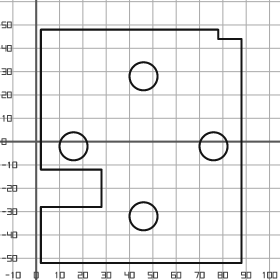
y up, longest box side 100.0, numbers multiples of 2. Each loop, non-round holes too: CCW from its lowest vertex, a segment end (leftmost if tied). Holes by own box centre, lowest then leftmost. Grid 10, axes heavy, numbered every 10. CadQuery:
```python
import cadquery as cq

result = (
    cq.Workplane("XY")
    .moveTo(2.0, -52.0)
    .lineTo(88.0, -52.0)
    .lineTo(88.0, 44.0)
    .lineTo(78.0, 44.0)
    .lineTo(78.0, 48.0)
    .lineTo(2.0, 48.0)
    .lineTo(2.0, -12.0)
    .lineTo(28.0, -12.0)
    .lineTo(28.0, -28.0)
    .lineTo(2.0, -28.0)
    .close()
    .moveTo(46.0, -32.0)
    .circle(6.0)
    .moveTo(16.0, -2.0)
    .circle(6.0)
    .moveTo(76.0, -2.0)
    .circle(6.0)
    .moveTo(46.0, 28.0)
    .circle(6.0)
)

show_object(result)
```